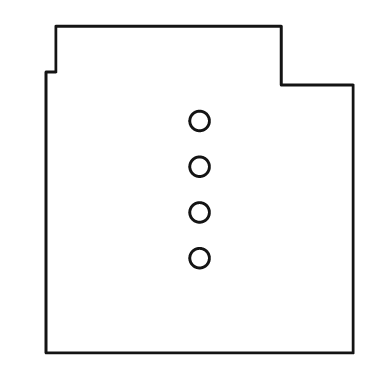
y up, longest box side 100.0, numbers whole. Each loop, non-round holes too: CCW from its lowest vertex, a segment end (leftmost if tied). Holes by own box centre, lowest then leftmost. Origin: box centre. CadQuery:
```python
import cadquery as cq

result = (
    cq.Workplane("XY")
    .moveTo(-47.0, -50.0)
    .lineTo(47.0, -50.0)
    .lineTo(47.0, 32.0)
    .lineTo(25.0, 32.0)
    .lineTo(25.0, 50.0)
    .lineTo(-44.0, 50.0)
    .lineTo(-44.0, 36.0)
    .lineTo(-47.0, 36.0)
    .close()
    .moveTo(0.0, -21.0)
    .circle(3.0)
    .moveTo(0.0, -7.0)
    .circle(3.0)
    .moveTo(0.0, 7.0)
    .circle(3.0)
    .moveTo(0.0, 21.0)
    .circle(3.0)
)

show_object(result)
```